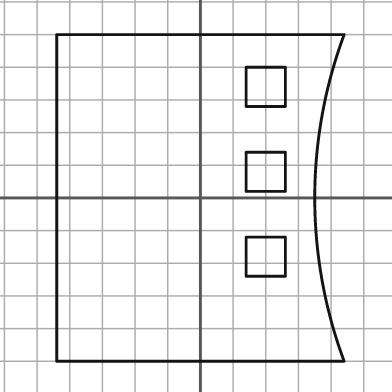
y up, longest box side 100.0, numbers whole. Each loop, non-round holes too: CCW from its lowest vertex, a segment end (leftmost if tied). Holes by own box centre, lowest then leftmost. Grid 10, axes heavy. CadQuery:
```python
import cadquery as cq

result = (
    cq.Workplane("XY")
    .moveTo(-44.0, -50.0)
    .lineTo(44.0, -50.0)
    .threePointArc((35.0, 0.0), (44.0, 50.0))
    .lineTo(-44.0, 50.0)
    .close()
    .moveTo(14.0, -24.0)
    .lineTo(26.0, -24.0)
    .lineTo(26.0, -12.0)
    .lineTo(14.0, -12.0)
    .close()
    .moveTo(14.0, 2.0)
    .lineTo(26.0, 2.0)
    .lineTo(26.0, 14.0)
    .lineTo(14.0, 14.0)
    .close()
    .moveTo(14.0, 28.0)
    .lineTo(26.0, 28.0)
    .lineTo(26.0, 40.0)
    .lineTo(14.0, 40.0)
    .close()
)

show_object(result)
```